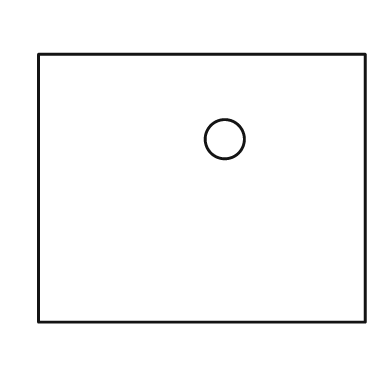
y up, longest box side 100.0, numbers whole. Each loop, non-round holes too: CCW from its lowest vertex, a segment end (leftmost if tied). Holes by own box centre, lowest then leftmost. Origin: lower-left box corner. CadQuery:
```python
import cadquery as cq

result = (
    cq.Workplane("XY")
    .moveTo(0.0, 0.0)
    .lineTo(100.0, 0.0)
    .lineTo(100.0, 82.0)
    .lineTo(0.0, 82.0)
    .close()
    .moveTo(57.0, 56.0)
    .circle(6.0)
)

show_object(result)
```